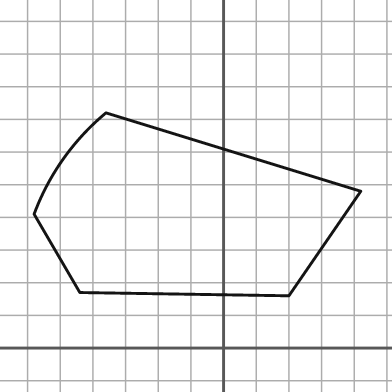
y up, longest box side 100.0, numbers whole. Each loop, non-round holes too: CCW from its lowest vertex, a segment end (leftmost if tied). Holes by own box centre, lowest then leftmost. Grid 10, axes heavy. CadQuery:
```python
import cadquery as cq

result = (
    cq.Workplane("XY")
    .moveTo(20.0, 16.0)
    .lineTo(42.0, 48.0)
    .lineTo(-36.0, 72.0)
    .threePointArc((-49.0, 58.0), (-58.0, 41.0))
    .lineTo(-44.0, 17.0)
    .close()
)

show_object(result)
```